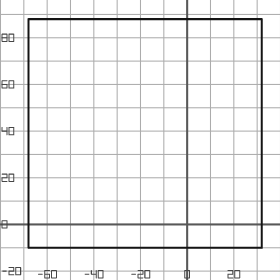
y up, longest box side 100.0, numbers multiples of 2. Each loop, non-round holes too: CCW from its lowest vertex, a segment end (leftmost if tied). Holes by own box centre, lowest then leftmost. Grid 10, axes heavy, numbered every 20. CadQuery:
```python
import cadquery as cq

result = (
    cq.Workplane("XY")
    .moveTo(-68.0, -10.0)
    .lineTo(32.0, -10.0)
    .lineTo(32.0, 88.0)
    .lineTo(-68.0, 88.0)
    .close()
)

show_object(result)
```